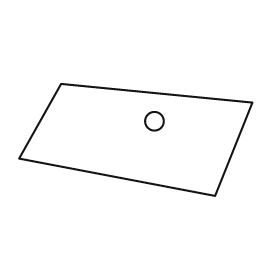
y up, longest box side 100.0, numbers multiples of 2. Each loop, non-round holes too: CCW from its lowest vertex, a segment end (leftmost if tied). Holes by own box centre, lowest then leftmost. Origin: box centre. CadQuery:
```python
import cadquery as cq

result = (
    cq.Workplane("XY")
    .moveTo(34.0, -24.0)
    .lineTo(50.0, 16.0)
    .lineTo(-32.0, 24.0)
    .lineTo(-50.0, -8.0)
    .close()
    .moveTo(8.0, 8.0)
    .circle(4.0)
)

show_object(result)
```